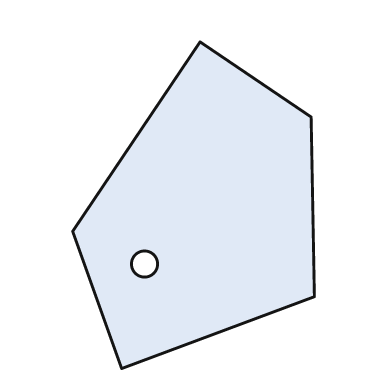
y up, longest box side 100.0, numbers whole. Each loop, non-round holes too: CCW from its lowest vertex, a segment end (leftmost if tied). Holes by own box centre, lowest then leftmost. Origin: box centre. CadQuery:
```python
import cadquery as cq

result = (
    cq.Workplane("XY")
    .moveTo(-22.0, -50.0)
    .lineTo(37.0, -28.0)
    .lineTo(36.0, 27.0)
    .lineTo(2.0, 50.0)
    .lineTo(-37.0, -8.0)
    .close()
    .moveTo(-15.0, -18.0)
    .circle(4.0)
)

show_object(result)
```